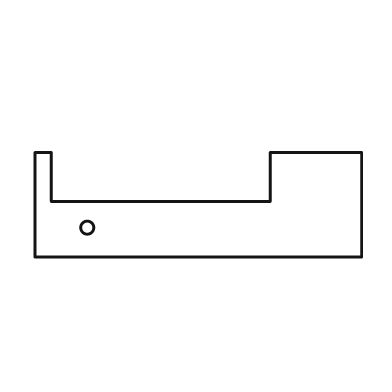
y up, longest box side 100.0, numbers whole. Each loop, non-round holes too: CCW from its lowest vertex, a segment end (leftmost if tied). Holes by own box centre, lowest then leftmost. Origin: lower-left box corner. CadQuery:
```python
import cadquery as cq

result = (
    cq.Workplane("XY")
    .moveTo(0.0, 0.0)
    .lineTo(100.0, 0.0)
    .lineTo(100.0, 32.0)
    .lineTo(72.0, 32.0)
    .lineTo(72.0, 17.0)
    .lineTo(5.0, 17.0)
    .lineTo(5.0, 32.0)
    .lineTo(0.0, 32.0)
    .close()
    .moveTo(16.0, 9.0)
    .circle(2.0)
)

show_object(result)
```